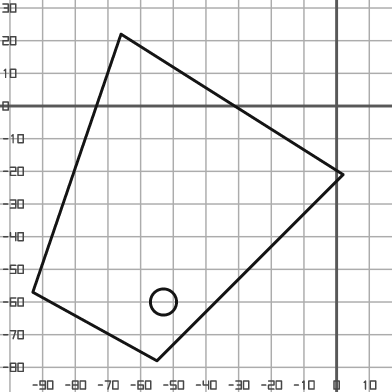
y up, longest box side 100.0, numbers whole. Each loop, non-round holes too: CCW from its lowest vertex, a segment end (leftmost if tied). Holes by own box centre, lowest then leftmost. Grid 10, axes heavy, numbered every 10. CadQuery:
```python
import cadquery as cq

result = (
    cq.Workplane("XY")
    .moveTo(-55.0, -78.0)
    .lineTo(2.0, -21.0)
    .lineTo(-66.0, 22.0)
    .lineTo(-93.0, -57.0)
    .close()
    .moveTo(-53.0, -60.0)
    .circle(4.0)
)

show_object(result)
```